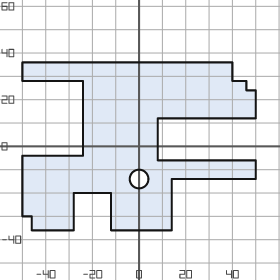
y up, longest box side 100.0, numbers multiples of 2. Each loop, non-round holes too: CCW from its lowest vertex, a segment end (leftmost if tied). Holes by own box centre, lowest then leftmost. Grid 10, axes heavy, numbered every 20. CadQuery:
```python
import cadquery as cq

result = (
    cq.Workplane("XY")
    .moveTo(-46.0, -36.0)
    .lineTo(-28.0, -36.0)
    .lineTo(-28.0, -20.0)
    .lineTo(-12.0, -20.0)
    .lineTo(-12.0, -36.0)
    .lineTo(14.0, -36.0)
    .lineTo(14.0, -14.0)
    .lineTo(50.0, -14.0)
    .lineTo(50.0, -6.0)
    .lineTo(8.0, -6.0)
    .lineTo(8.0, 12.0)
    .lineTo(50.0, 12.0)
    .lineTo(50.0, 24.0)
    .lineTo(46.0, 24.0)
    .lineTo(46.0, 28.0)
    .lineTo(40.0, 28.0)
    .lineTo(40.0, 36.0)
    .lineTo(-50.0, 36.0)
    .lineTo(-50.0, 28.0)
    .lineTo(-24.0, 28.0)
    .lineTo(-24.0, -4.0)
    .lineTo(-50.0, -4.0)
    .lineTo(-50.0, -30.0)
    .lineTo(-46.0, -30.0)
    .close()
    .moveTo(0.0, -14.0)
    .circle(4.0)
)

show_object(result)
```